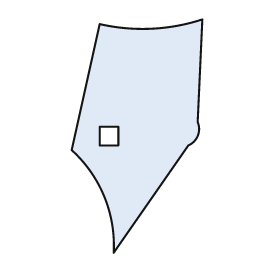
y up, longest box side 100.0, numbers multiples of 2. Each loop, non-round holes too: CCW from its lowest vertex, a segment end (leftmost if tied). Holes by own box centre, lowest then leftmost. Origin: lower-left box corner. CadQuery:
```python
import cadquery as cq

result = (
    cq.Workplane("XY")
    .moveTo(18.0, 0.0)
    .lineTo(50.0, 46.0)
    .threePointArc((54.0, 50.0), (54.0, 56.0))
    .lineTo(56.0, 100.0)
    .threePointArc((34.0, 96.0), (12.0, 98.0))
    .lineTo(0.0, 44.0)
    .threePointArc((14.0, 24.0), (18.0, 0.0))
    .close()
    .moveTo(12.0, 46.0)
    .lineTo(20.0, 46.0)
    .lineTo(20.0, 54.0)
    .lineTo(12.0, 54.0)
    .close()
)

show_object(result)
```